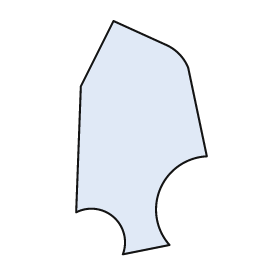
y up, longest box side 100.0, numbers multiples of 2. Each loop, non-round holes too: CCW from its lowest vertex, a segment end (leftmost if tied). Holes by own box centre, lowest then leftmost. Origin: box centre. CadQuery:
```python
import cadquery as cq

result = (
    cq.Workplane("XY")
    .moveTo(-8.0, -50.0)
    .lineTo(12.0, -46.0)
    .threePointArc((8.0, -22.0), (28.0, -8.0))
    .lineTo(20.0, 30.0)
    .threePointArc((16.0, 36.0), (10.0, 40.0))
    .lineTo(-12.0, 50.0)
    .lineTo(-26.0, 22.0)
    .lineTo(-28.0, -32.0)
    .threePointArc((-12.0, -34.0), (-8.0, -50.0))
    .close()
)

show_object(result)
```